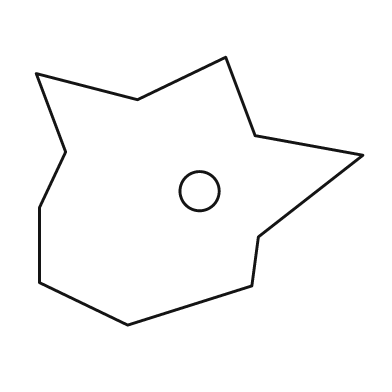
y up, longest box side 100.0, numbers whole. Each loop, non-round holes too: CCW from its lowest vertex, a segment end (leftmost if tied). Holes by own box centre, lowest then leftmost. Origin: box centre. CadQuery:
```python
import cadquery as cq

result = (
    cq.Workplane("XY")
    .moveTo(-22.0, -41.0)
    .lineTo(16.0, -29.0)
    .lineTo(18.0, -14.0)
    .lineTo(50.0, 11.0)
    .lineTo(17.0, 17.0)
    .lineTo(8.0, 41.0)
    .lineTo(-19.0, 28.0)
    .lineTo(-50.0, 36.0)
    .lineTo(-41.0, 12.0)
    .lineTo(-49.0, -5.0)
    .lineTo(-49.0, -28.0)
    .close()
    .moveTo(0.0, 0.0)
    .circle(6.0)
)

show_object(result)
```